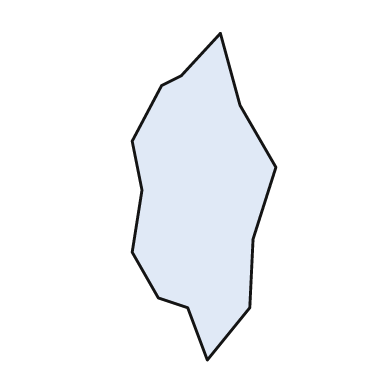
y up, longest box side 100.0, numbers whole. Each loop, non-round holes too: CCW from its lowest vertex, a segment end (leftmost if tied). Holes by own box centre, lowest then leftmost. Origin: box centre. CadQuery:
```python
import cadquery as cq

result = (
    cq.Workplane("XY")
    .moveTo(1.0, -50.0)
    .lineTo(14.0, -34.0)
    .lineTo(15.0, -13.0)
    .lineTo(22.0, 9.0)
    .lineTo(11.0, 28.0)
    .lineTo(5.0, 50.0)
    .lineTo(-7.0, 37.0)
    .lineTo(-13.0, 34.0)
    .lineTo(-22.0, 17.0)
    .lineTo(-19.0, 2.0)
    .lineTo(-22.0, -17.0)
    .lineTo(-14.0, -31.0)
    .lineTo(-5.0, -34.0)
    .close()
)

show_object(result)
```